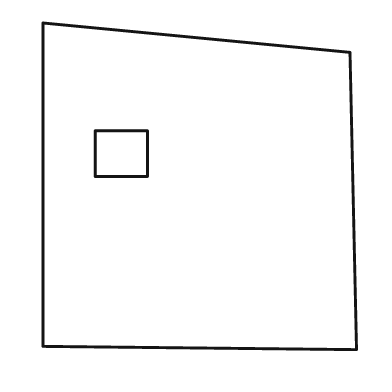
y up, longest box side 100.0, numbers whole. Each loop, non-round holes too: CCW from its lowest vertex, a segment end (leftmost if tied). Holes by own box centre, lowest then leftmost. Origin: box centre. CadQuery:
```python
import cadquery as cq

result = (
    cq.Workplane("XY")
    .moveTo(48.0, -50.0)
    .lineTo(46.0, 41.0)
    .lineTo(-48.0, 50.0)
    .lineTo(-48.0, -49.0)
    .close()
    .moveTo(-32.0, 3.0)
    .lineTo(-16.0, 3.0)
    .lineTo(-16.0, 17.0)
    .lineTo(-32.0, 17.0)
    .close()
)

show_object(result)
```